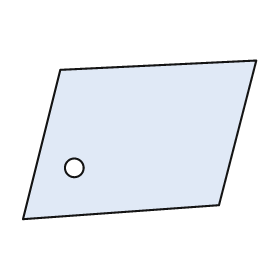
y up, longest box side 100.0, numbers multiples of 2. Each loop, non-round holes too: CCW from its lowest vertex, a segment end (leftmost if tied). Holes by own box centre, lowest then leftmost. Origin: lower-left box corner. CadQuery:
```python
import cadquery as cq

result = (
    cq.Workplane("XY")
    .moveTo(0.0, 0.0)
    .lineTo(84.0, 6.0)
    .lineTo(100.0, 68.0)
    .lineTo(16.0, 64.0)
    .close()
    .moveTo(22.0, 22.0)
    .circle(4.0)
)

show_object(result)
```